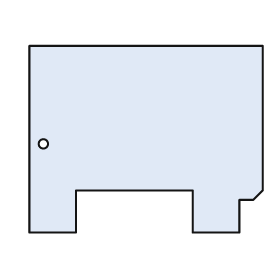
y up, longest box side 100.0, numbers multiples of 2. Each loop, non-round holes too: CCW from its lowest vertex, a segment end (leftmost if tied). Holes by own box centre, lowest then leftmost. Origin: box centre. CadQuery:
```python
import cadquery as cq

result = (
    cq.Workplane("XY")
    .moveTo(-50.0, -40.0)
    .lineTo(-30.0, -40.0)
    .lineTo(-30.0, -22.0)
    .lineTo(20.0, -22.0)
    .lineTo(20.0, -40.0)
    .lineTo(40.0, -40.0)
    .lineTo(40.0, -26.0)
    .lineTo(46.0, -26.0)
    .lineTo(50.0, -22.0)
    .lineTo(50.0, 40.0)
    .lineTo(-50.0, 40.0)
    .close()
    .moveTo(-44.0, -2.0)
    .circle(2.0)
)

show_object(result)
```